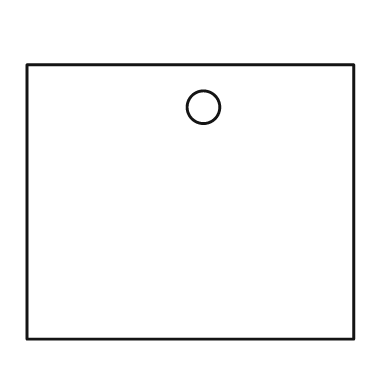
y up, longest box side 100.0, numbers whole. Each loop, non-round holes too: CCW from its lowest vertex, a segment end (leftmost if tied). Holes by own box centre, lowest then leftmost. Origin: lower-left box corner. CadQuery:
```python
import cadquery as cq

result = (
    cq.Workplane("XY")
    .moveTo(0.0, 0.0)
    .lineTo(100.0, 0.0)
    .lineTo(100.0, 84.0)
    .lineTo(0.0, 84.0)
    .close()
    .moveTo(54.0, 71.0)
    .circle(5.0)
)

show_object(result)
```